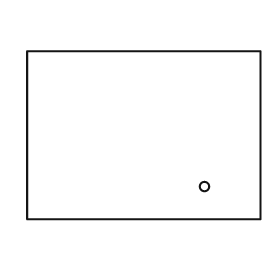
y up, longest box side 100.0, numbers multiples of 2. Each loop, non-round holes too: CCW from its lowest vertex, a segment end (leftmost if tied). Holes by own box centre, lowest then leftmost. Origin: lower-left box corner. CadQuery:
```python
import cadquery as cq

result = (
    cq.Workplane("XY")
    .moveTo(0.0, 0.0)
    .lineTo(100.0, 0.0)
    .lineTo(100.0, 72.0)
    .lineTo(0.0, 72.0)
    .close()
    .moveTo(76.0, 14.0)
    .circle(2.0)
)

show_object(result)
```